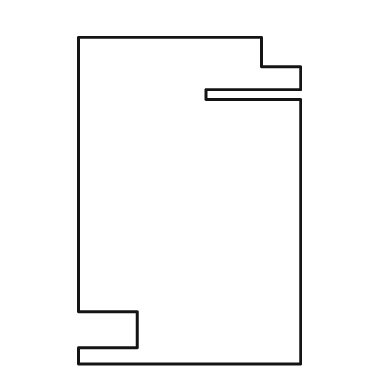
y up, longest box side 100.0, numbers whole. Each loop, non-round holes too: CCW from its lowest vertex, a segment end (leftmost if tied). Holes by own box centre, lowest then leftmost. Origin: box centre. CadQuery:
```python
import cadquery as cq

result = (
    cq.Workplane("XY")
    .moveTo(-34.0, -50.0)
    .lineTo(34.0, -50.0)
    .lineTo(34.0, 31.0)
    .lineTo(5.0, 31.0)
    .lineTo(5.0, 34.0)
    .lineTo(34.0, 34.0)
    .lineTo(34.0, 41.0)
    .lineTo(22.0, 41.0)
    .lineTo(22.0, 50.0)
    .lineTo(-34.0, 50.0)
    .lineTo(-34.0, -34.0)
    .lineTo(-16.0, -34.0)
    .lineTo(-16.0, -45.0)
    .lineTo(-34.0, -45.0)
    .close()
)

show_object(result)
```